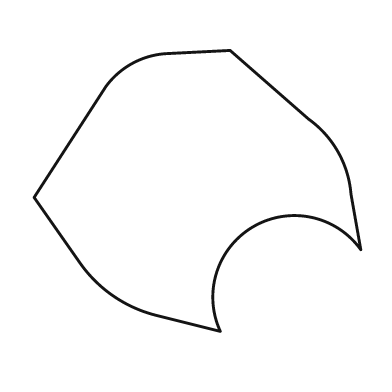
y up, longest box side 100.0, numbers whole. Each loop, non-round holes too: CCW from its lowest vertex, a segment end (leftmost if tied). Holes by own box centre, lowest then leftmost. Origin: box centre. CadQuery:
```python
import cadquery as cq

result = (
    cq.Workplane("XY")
    .moveTo(7.0, -43.0)
    .threePointArc((17.0, -11.0), (50.0, -18.0))
    .lineTo(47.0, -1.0)
    .threePointArc((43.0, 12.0), (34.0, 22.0))
    .lineTo(10.0, 43.0)
    .lineTo(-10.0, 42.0)
    .threePointArc((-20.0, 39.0), (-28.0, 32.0))
    .lineTo(-50.0, -2.0)
    .lineTo(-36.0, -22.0)
    .threePointArc((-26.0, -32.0), (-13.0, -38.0))
    .close()
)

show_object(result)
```